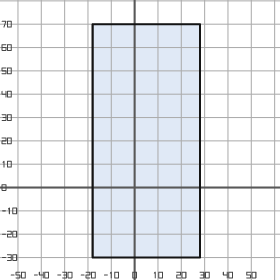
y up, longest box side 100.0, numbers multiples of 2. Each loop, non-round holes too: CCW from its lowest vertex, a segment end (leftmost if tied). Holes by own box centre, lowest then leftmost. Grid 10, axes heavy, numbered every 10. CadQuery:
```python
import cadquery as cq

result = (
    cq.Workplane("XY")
    .moveTo(-18.0, -30.0)
    .lineTo(28.0, -30.0)
    .lineTo(28.0, 70.0)
    .lineTo(-18.0, 70.0)
    .close()
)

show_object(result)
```